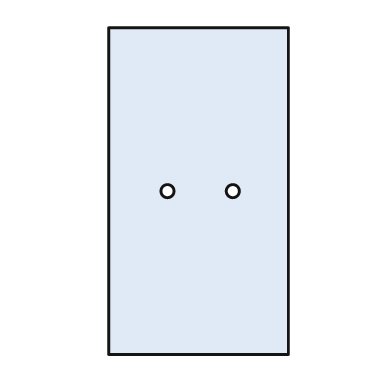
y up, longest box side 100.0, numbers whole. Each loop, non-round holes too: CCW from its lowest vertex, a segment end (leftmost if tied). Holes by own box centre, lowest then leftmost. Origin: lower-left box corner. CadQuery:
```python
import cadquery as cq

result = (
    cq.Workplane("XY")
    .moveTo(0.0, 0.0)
    .lineTo(55.0, 0.0)
    .lineTo(55.0, 100.0)
    .lineTo(0.0, 100.0)
    .close()
    .moveTo(18.0, 50.0)
    .circle(2.0)
    .moveTo(38.0, 50.0)
    .circle(2.0)
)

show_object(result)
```